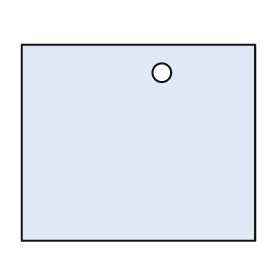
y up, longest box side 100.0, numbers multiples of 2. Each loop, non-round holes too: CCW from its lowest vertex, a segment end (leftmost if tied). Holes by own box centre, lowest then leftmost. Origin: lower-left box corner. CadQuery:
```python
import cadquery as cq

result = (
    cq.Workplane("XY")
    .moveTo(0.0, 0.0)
    .lineTo(100.0, 0.0)
    .lineTo(100.0, 84.0)
    .lineTo(0.0, 84.0)
    .close()
    .moveTo(60.0, 72.0)
    .circle(4.0)
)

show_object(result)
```